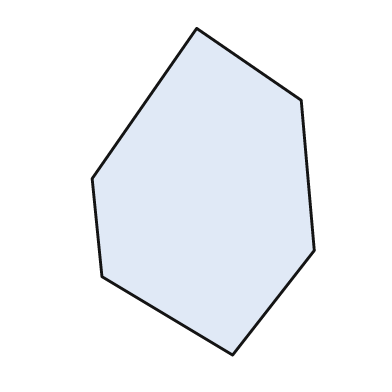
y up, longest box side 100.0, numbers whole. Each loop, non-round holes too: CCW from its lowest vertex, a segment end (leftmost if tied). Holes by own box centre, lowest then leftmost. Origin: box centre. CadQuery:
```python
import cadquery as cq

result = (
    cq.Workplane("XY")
    .moveTo(9.0, -50.0)
    .lineTo(34.0, -18.0)
    .lineTo(30.0, 28.0)
    .lineTo(-2.0, 50.0)
    .lineTo(-34.0, 4.0)
    .lineTo(-31.0, -26.0)
    .close()
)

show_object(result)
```